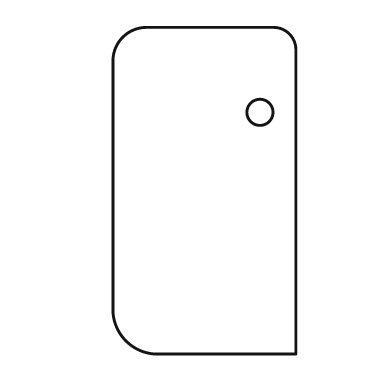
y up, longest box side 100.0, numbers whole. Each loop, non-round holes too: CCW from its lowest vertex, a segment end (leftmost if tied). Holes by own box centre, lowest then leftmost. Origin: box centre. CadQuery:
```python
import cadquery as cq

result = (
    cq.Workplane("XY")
    .moveTo(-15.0, -50.0)
    .lineTo(28.0, -50.0)
    .lineTo(28.0, 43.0)
    .threePointArc((26.0, 48.0), (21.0, 50.0))
    .lineTo(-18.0, 50.0)
    .threePointArc((-25.0, 47.0), (-28.0, 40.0))
    .lineTo(-28.0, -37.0)
    .threePointArc((-24.0, -46.0), (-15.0, -50.0))
    .close()
    .moveTo(17.0, 24.0)
    .circle(4.0)
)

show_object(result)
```